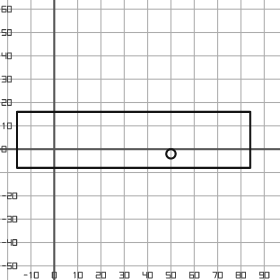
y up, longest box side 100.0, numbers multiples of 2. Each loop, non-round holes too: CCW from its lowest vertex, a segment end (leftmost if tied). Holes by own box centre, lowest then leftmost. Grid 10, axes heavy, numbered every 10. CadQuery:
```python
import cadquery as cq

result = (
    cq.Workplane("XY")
    .moveTo(-16.0, -8.0)
    .lineTo(84.0, -8.0)
    .lineTo(84.0, 16.0)
    .lineTo(-16.0, 16.0)
    .close()
    .moveTo(50.0, -2.0)
    .circle(2.0)
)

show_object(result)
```